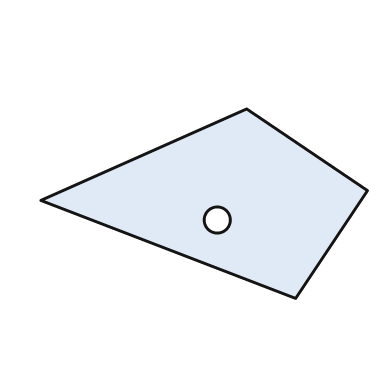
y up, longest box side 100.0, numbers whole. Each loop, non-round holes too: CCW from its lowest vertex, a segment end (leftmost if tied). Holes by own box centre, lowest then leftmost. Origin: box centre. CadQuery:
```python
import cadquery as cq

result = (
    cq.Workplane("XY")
    .moveTo(28.0, -29.0)
    .lineTo(50.0, 4.0)
    .lineTo(13.0, 29.0)
    .lineTo(-50.0, 1.0)
    .close()
    .moveTo(4.0, -5.0)
    .circle(4.0)
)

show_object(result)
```